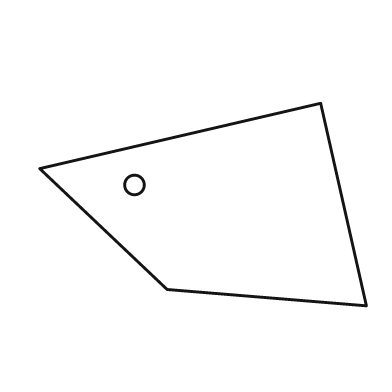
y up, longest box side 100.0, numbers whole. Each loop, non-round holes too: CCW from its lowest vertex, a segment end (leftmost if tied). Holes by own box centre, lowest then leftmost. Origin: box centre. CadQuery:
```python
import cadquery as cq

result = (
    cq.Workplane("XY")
    .moveTo(50.0, -31.0)
    .lineTo(36.0, 31.0)
    .lineTo(-50.0, 11.0)
    .lineTo(-11.0, -26.0)
    .close()
    .moveTo(-21.0, 6.0)
    .circle(3.0)
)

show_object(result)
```